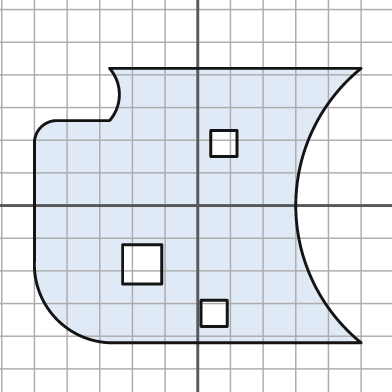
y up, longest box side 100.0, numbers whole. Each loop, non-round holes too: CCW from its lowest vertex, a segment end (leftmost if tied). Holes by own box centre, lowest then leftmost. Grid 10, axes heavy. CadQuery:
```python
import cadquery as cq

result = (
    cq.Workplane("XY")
    .moveTo(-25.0, -42.0)
    .lineTo(50.0, -42.0)
    .threePointArc((30.0, 0.0), (50.0, 42.0))
    .lineTo(-27.0, 42.0)
    .threePointArc((-24.0, 34.0), (-27.0, 26.0))
    .lineTo(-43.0, 26.0)
    .threePointArc((-48.0, 24.0), (-50.0, 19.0))
    .lineTo(-50.0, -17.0)
    .threePointArc((-43.0, -35.0), (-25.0, -42.0))
    .close()
    .moveTo(1.0, -37.0)
    .lineTo(9.0, -37.0)
    .lineTo(9.0, -29.0)
    .lineTo(1.0, -29.0)
    .close()
    .moveTo(-23.0, -24.0)
    .lineTo(-11.0, -24.0)
    .lineTo(-11.0, -12.0)
    .lineTo(-23.0, -12.0)
    .close()
    .moveTo(4.0, 15.0)
    .lineTo(12.0, 15.0)
    .lineTo(12.0, 23.0)
    .lineTo(4.0, 23.0)
    .close()
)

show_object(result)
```